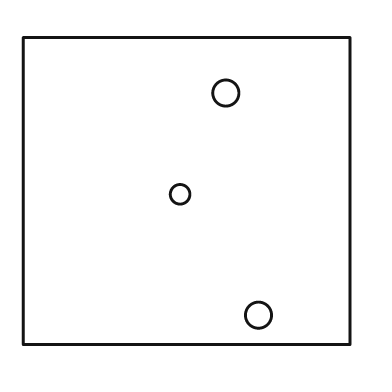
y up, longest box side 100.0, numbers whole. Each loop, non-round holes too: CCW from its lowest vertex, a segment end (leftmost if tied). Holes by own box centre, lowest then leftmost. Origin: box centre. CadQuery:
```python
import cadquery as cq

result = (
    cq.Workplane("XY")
    .moveTo(-50.0, -47.0)
    .lineTo(50.0, -47.0)
    .lineTo(50.0, 47.0)
    .lineTo(-50.0, 47.0)
    .close()
    .moveTo(22.0, -38.0)
    .circle(4.0)
    .moveTo(-2.0, -1.0)
    .circle(3.0)
    .moveTo(12.0, 30.0)
    .circle(4.0)
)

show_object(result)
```